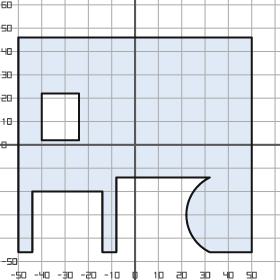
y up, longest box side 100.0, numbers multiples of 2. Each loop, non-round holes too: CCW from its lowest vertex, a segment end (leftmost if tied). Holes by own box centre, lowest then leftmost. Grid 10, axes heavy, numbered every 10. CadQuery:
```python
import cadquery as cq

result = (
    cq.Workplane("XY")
    .moveTo(-50.0, -46.0)
    .lineTo(-44.0, -46.0)
    .lineTo(-44.0, -20.0)
    .lineTo(-14.0, -20.0)
    .lineTo(-14.0, -46.0)
    .lineTo(-8.0, -46.0)
    .lineTo(-8.0, -14.0)
    .lineTo(32.0, -14.0)
    .threePointArc((22.0, -30.0), (32.0, -46.0))
    .lineTo(50.0, -46.0)
    .lineTo(50.0, 46.0)
    .lineTo(-50.0, 46.0)
    .close()
    .moveTo(-40.0, 2.0)
    .lineTo(-24.0, 2.0)
    .lineTo(-24.0, 22.0)
    .lineTo(-40.0, 22.0)
    .close()
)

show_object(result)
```